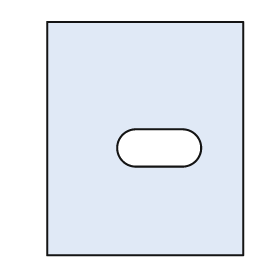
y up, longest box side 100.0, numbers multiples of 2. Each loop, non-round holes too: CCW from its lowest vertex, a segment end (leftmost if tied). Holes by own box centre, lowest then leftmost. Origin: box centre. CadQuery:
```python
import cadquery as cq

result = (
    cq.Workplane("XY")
    .moveTo(-42.0, -50.0)
    .lineTo(42.0, -50.0)
    .lineTo(42.0, 50.0)
    .lineTo(-42.0, 50.0)
    .close()
    .moveTo(-4.0, -12.0)
    .lineTo(16.0, -12.0)
    .threePointArc((24.0, -4.0), (16.0, 4.0))
    .lineTo(-4.0, 4.0)
    .threePointArc((-12.0, -4.0), (-4.0, -12.0))
    .close()
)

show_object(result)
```